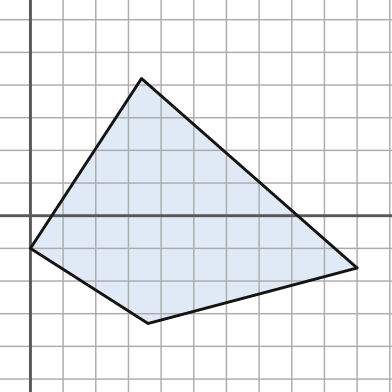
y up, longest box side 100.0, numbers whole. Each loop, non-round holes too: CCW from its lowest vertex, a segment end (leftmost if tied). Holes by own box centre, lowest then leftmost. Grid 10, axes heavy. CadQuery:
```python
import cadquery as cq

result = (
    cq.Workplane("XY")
    .moveTo(36.0, -33.0)
    .lineTo(100.0, -16.0)
    .lineTo(34.0, 42.0)
    .lineTo(0.0, -10.0)
    .close()
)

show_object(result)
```